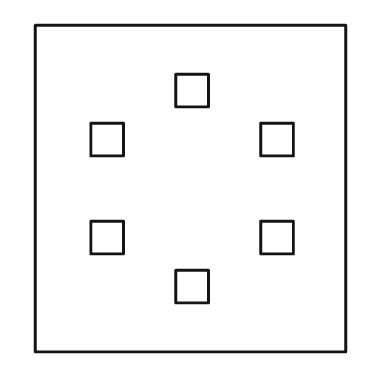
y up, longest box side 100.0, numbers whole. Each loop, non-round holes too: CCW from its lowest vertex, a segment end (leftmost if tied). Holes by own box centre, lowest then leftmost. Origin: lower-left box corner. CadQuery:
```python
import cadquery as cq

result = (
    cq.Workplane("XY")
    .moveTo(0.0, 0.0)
    .lineTo(95.0, 0.0)
    .lineTo(95.0, 100.0)
    .lineTo(0.0, 100.0)
    .close()
    .moveTo(43.0, 15.0)
    .lineTo(53.0, 15.0)
    .lineTo(53.0, 25.0)
    .lineTo(43.0, 25.0)
    .close()
    .moveTo(17.0, 30.0)
    .lineTo(27.0, 30.0)
    .lineTo(27.0, 40.0)
    .lineTo(17.0, 40.0)
    .close()
    .moveTo(69.0, 30.0)
    .lineTo(79.0, 30.0)
    .lineTo(79.0, 40.0)
    .lineTo(69.0, 40.0)
    .close()
    .moveTo(17.0, 60.0)
    .lineTo(27.0, 60.0)
    .lineTo(27.0, 70.0)
    .lineTo(17.0, 70.0)
    .close()
    .moveTo(69.0, 60.0)
    .lineTo(79.0, 60.0)
    .lineTo(79.0, 70.0)
    .lineTo(69.0, 70.0)
    .close()
    .moveTo(43.0, 75.0)
    .lineTo(53.0, 75.0)
    .lineTo(53.0, 85.0)
    .lineTo(43.0, 85.0)
    .close()
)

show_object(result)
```